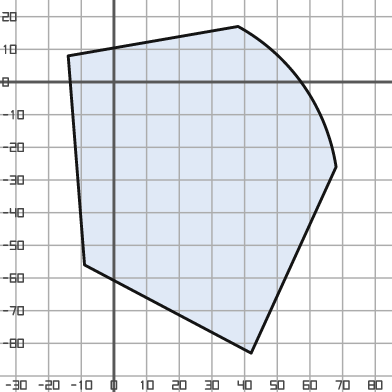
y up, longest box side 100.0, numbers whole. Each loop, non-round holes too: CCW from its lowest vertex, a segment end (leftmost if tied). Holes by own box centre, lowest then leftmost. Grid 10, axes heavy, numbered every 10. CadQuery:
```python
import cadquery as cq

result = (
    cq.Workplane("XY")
    .moveTo(42.0, -83.0)
    .lineTo(68.0, -26.0)
    .threePointArc((58.0, -1.0), (38.0, 17.0))
    .lineTo(-14.0, 8.0)
    .lineTo(-9.0, -56.0)
    .close()
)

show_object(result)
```